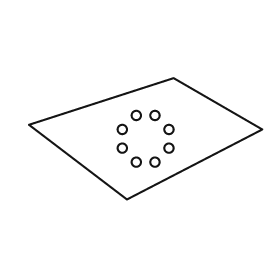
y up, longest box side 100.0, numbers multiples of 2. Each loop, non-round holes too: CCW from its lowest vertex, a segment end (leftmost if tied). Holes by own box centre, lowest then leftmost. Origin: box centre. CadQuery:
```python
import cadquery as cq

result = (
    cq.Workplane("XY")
    .moveTo(-8.0, -26.0)
    .lineTo(50.0, 4.0)
    .lineTo(12.0, 26.0)
    .lineTo(-50.0, 6.0)
    .close()
    .moveTo(-4.0, -10.0)
    .circle(2.0)
    .moveTo(4.0, -10.0)
    .circle(2.0)
    .moveTo(-10.0, -4.0)
    .circle(2.0)
    .moveTo(10.0, -4.0)
    .circle(2.0)
    .moveTo(-10.0, 4.0)
    .circle(2.0)
    .moveTo(10.0, 4.0)
    .circle(2.0)
    .moveTo(-4.0, 10.0)
    .circle(2.0)
    .moveTo(4.0, 10.0)
    .circle(2.0)
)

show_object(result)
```